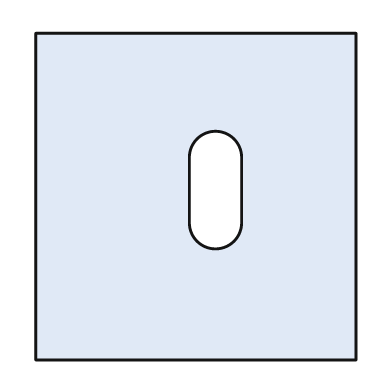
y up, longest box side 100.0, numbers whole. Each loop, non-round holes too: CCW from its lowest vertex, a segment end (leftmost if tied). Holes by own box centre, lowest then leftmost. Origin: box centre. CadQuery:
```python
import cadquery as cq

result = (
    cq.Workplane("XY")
    .moveTo(-49.0, -50.0)
    .lineTo(49.0, -50.0)
    .lineTo(49.0, 50.0)
    .lineTo(-49.0, 50.0)
    .close()
    .moveTo(-2.0, -8.0)
    .threePointArc((6.0, -16.0), (14.0, -8.0))
    .lineTo(14.0, 12.0)
    .threePointArc((6.0, 20.0), (-2.0, 12.0))
    .close()
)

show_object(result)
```